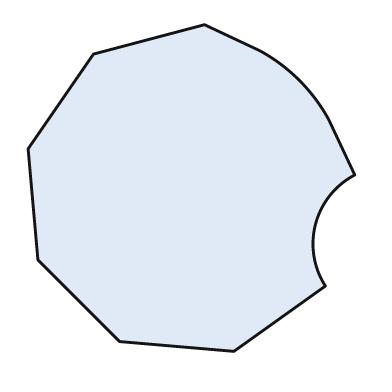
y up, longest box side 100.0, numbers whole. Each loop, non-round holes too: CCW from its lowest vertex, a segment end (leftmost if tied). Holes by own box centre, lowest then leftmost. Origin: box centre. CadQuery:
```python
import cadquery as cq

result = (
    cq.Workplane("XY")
    .moveTo(13.0, -50.0)
    .lineTo(41.0, -30.0)
    .threePointArc((38.0, -11.0), (50.0, 4.0))
    .lineTo(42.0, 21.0)
    .threePointArc((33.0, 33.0), (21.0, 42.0))
    .lineTo(4.0, 50.0)
    .lineTo(-30.0, 41.0)
    .lineTo(-50.0, 12.0)
    .lineTo(-47.0, -22.0)
    .lineTo(-22.0, -47.0)
    .close()
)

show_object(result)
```